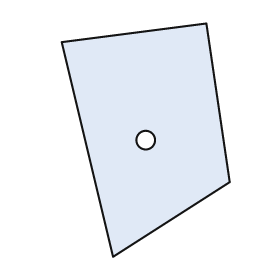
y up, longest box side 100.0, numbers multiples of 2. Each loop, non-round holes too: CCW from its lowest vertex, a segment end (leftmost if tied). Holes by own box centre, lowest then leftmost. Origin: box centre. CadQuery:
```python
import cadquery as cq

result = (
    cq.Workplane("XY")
    .moveTo(-14.0, -50.0)
    .lineTo(36.0, -18.0)
    .lineTo(26.0, 50.0)
    .lineTo(-36.0, 42.0)
    .close()
    .moveTo(0.0, 0.0)
    .circle(4.0)
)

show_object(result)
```